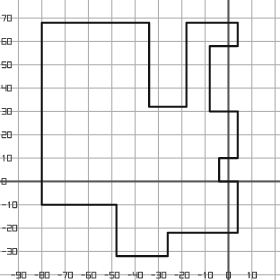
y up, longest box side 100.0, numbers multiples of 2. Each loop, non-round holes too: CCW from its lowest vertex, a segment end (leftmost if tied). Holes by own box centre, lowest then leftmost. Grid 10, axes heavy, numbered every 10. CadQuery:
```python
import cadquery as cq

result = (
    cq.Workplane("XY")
    .moveTo(-48.0, -32.0)
    .lineTo(-26.0, -32.0)
    .lineTo(-26.0, -22.0)
    .lineTo(4.0, -22.0)
    .lineTo(4.0, 0.0)
    .lineTo(-4.0, 0.0)
    .lineTo(-4.0, 10.0)
    .lineTo(4.0, 10.0)
    .lineTo(4.0, 30.0)
    .lineTo(-8.0, 30.0)
    .lineTo(-8.0, 58.0)
    .lineTo(4.0, 58.0)
    .lineTo(4.0, 68.0)
    .lineTo(-18.0, 68.0)
    .lineTo(-18.0, 32.0)
    .lineTo(-34.0, 32.0)
    .lineTo(-34.0, 68.0)
    .lineTo(-80.0, 68.0)
    .lineTo(-80.0, -10.0)
    .lineTo(-48.0, -10.0)
    .close()
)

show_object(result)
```